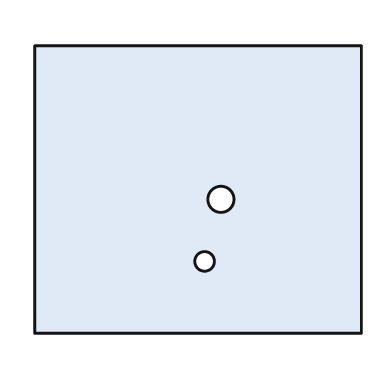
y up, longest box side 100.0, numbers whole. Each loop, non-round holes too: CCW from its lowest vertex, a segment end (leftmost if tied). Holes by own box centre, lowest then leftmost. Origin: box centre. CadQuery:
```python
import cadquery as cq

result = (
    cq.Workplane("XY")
    .moveTo(-50.0, -44.0)
    .lineTo(50.0, -44.0)
    .lineTo(50.0, 44.0)
    .lineTo(-50.0, 44.0)
    .close()
    .moveTo(2.0, -22.0)
    .circle(3.0)
    .moveTo(7.0, -3.0)
    .circle(4.0)
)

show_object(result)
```